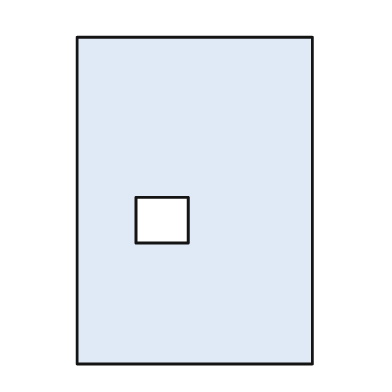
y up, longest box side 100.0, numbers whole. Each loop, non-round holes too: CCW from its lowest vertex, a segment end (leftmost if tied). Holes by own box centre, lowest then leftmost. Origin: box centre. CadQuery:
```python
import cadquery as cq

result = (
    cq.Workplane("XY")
    .moveTo(-36.0, -50.0)
    .lineTo(36.0, -50.0)
    .lineTo(36.0, 50.0)
    .lineTo(-36.0, 50.0)
    .close()
    .moveTo(-18.0, -13.0)
    .lineTo(-2.0, -13.0)
    .lineTo(-2.0, 1.0)
    .lineTo(-18.0, 1.0)
    .close()
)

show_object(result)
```